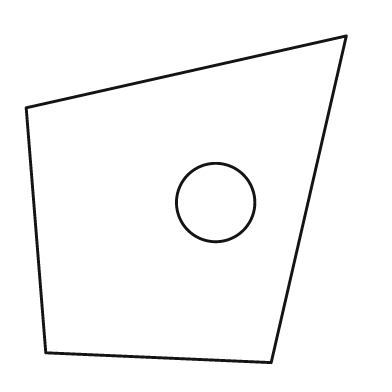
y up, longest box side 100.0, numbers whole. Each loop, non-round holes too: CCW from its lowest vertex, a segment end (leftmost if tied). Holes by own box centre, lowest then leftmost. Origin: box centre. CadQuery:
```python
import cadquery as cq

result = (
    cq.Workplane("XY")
    .moveTo(26.0, -50.0)
    .lineTo(49.0, 50.0)
    .lineTo(-49.0, 28.0)
    .lineTo(-43.0, -47.0)
    .close()
    .moveTo(9.0, -1.0)
    .circle(12.0)
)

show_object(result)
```